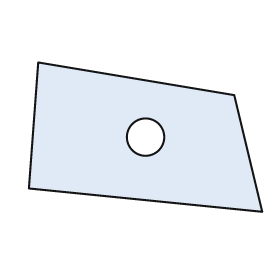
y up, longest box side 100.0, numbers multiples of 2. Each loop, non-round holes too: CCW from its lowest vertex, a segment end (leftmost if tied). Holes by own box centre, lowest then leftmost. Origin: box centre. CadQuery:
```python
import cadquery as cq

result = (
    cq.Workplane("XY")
    .moveTo(50.0, -32.0)
    .lineTo(38.0, 18.0)
    .lineTo(-46.0, 32.0)
    .lineTo(-50.0, -22.0)
    .close()
    .moveTo(0.0, 0.0)
    .circle(8.0)
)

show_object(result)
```